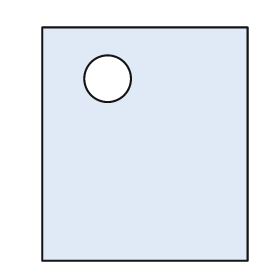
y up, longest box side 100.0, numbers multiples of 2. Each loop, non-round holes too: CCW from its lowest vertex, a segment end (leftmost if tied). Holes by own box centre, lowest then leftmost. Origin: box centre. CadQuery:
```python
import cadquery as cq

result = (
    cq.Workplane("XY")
    .moveTo(-44.0, -50.0)
    .lineTo(44.0, -50.0)
    .lineTo(44.0, 50.0)
    .lineTo(-44.0, 50.0)
    .close()
    .moveTo(-16.0, 28.0)
    .circle(10.0)
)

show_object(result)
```